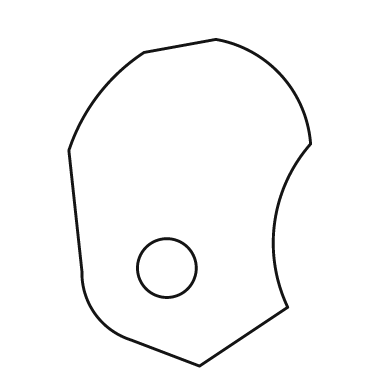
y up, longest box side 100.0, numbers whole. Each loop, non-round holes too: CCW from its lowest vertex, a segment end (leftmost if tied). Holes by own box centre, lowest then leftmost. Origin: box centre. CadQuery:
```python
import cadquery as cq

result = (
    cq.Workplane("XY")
    .moveTo(3.0, -50.0)
    .lineTo(30.0, -32.0)
    .threePointArc((26.0, -6.0), (37.0, 18.0))
    .threePointArc((28.0, 39.0), (8.0, 50.0))
    .lineTo(-14.0, 46.0)
    .threePointArc((-28.0, 33.0), (-37.0, 16.0))
    .lineTo(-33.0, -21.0)
    .threePointArc((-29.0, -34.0), (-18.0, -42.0))
    .close()
    .moveTo(-7.0, -20.0)
    .circle(9.0)
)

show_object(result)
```